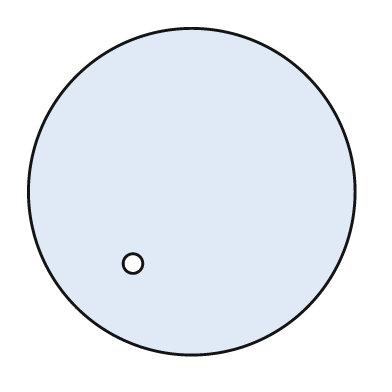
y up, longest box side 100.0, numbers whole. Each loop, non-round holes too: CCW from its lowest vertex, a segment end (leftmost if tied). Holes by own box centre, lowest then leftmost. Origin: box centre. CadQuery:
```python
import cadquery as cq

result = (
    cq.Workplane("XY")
    .moveTo(0.0, 0.0)
    .circle(50.0)
    .moveTo(-18.0, -22.0)
    .circle(3.0)
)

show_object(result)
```